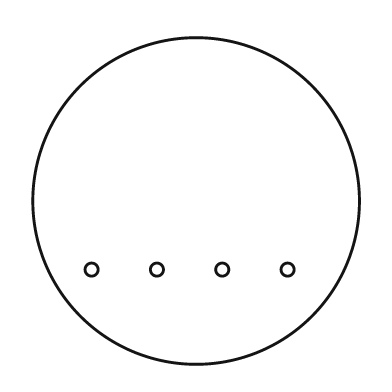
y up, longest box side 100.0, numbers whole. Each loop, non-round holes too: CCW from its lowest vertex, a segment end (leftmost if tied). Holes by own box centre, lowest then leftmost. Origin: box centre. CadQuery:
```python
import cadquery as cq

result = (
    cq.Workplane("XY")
    .moveTo(0.0, 0.0)
    .circle(50.0)
    .moveTo(-32.0, -21.0)
    .circle(2.0)
    .moveTo(-12.0, -21.0)
    .circle(2.0)
    .moveTo(8.0, -21.0)
    .circle(2.0)
    .moveTo(28.0, -21.0)
    .circle(2.0)
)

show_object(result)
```